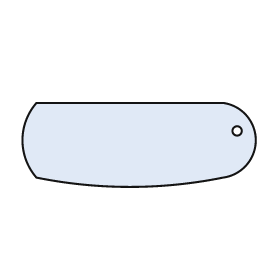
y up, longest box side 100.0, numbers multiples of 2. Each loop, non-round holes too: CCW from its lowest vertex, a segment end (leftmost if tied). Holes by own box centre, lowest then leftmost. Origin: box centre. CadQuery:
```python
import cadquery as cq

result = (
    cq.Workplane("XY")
    .moveTo(-44.0, -14.0)
    .threePointArc((-4.0, -18.0), (36.0, -14.0))
    .threePointArc((50.0, 2.0), (36.0, 18.0))
    .lineTo(-44.0, 18.0)
    .threePointArc((-50.0, 2.0), (-44.0, -14.0))
    .close()
    .moveTo(42.0, 6.0)
    .circle(2.0)
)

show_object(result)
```